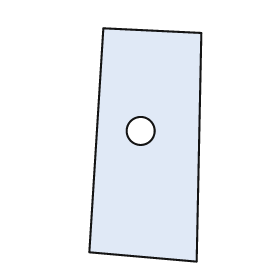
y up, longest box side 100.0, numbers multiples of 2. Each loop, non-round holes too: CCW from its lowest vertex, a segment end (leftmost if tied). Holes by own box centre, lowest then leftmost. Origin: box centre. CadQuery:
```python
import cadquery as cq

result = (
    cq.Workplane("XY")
    .moveTo(22.0, -50.0)
    .lineTo(24.0, 48.0)
    .lineTo(-18.0, 50.0)
    .lineTo(-24.0, -46.0)
    .close()
    .moveTo(-2.0, 6.0)
    .circle(6.0)
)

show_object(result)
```